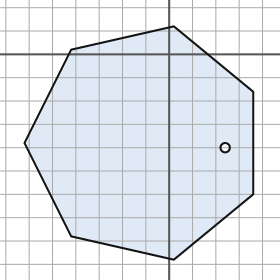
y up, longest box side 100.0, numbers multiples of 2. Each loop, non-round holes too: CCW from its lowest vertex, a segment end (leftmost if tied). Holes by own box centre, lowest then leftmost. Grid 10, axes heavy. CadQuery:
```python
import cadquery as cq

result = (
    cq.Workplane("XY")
    .moveTo(2.0, -88.0)
    .lineTo(36.0, -60.0)
    .lineTo(36.0, -16.0)
    .lineTo(2.0, 12.0)
    .lineTo(-42.0, 2.0)
    .lineTo(-62.0, -38.0)
    .lineTo(-42.0, -78.0)
    .close()
    .moveTo(24.0, -40.0)
    .circle(2.0)
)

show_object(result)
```